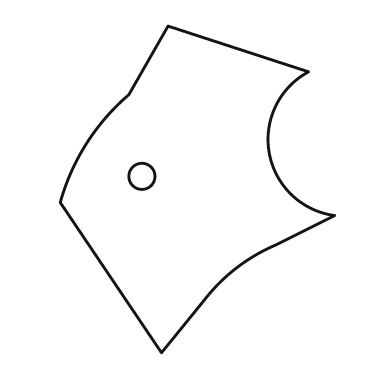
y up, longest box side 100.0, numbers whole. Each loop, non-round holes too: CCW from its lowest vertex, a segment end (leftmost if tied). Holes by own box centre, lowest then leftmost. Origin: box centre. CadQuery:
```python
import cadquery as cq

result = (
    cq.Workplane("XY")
    .moveTo(-11.0, -50.0)
    .lineTo(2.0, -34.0)
    .threePointArc((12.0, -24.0), (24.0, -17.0))
    .lineTo(42.0, -8.0)
    .threePointArc((22.0, 11.0), (34.0, 36.0))
    .lineTo(-9.0, 50.0)
    .lineTo(-21.0, 29.0)
    .threePointArc((-34.0, 14.0), (-42.0, -4.0))
    .close()
    .moveTo(-17.0, 4.0)
    .circle(4.0)
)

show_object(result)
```